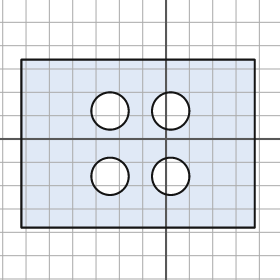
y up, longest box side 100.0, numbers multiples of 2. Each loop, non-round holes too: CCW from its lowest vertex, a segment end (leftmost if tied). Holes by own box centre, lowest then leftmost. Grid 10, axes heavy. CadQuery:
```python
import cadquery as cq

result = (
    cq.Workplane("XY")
    .moveTo(-62.0, -38.0)
    .lineTo(38.0, -38.0)
    .lineTo(38.0, 34.0)
    .lineTo(-62.0, 34.0)
    .close()
    .moveTo(-24.0, -16.0)
    .circle(8.0)
    .moveTo(2.0, -16.0)
    .circle(8.0)
    .moveTo(-24.0, 12.0)
    .circle(8.0)
    .moveTo(2.0, 12.0)
    .circle(8.0)
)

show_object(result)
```